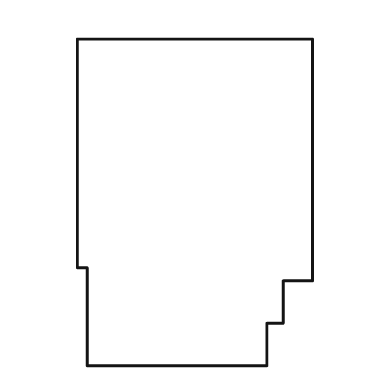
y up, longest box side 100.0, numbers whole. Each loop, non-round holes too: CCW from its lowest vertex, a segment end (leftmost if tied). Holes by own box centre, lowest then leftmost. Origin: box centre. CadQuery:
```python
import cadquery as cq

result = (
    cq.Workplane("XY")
    .moveTo(-33.0, -50.0)
    .lineTo(22.0, -50.0)
    .lineTo(22.0, -37.0)
    .lineTo(27.0, -37.0)
    .lineTo(27.0, -24.0)
    .lineTo(36.0, -24.0)
    .lineTo(36.0, 50.0)
    .lineTo(-36.0, 50.0)
    .lineTo(-36.0, -20.0)
    .lineTo(-33.0, -20.0)
    .close()
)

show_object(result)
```